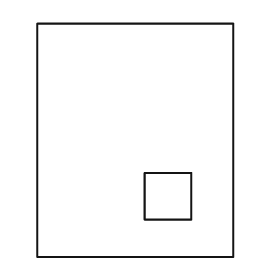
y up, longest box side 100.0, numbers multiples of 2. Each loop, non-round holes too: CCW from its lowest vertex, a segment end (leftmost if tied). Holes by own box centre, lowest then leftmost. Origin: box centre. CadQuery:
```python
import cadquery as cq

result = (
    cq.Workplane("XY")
    .moveTo(-42.0, -50.0)
    .lineTo(42.0, -50.0)
    .lineTo(42.0, 50.0)
    .lineTo(-42.0, 50.0)
    .close()
    .moveTo(4.0, -34.0)
    .lineTo(24.0, -34.0)
    .lineTo(24.0, -14.0)
    .lineTo(4.0, -14.0)
    .close()
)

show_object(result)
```